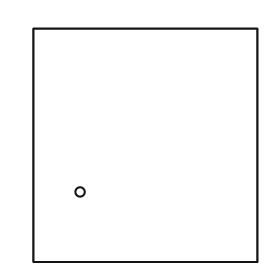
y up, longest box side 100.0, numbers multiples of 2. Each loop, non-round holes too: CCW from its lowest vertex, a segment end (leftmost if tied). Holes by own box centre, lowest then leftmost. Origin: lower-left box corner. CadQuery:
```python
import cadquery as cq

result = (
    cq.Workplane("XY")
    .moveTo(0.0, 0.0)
    .lineTo(96.0, 0.0)
    .lineTo(96.0, 100.0)
    .lineTo(0.0, 100.0)
    .close()
    .moveTo(20.0, 30.0)
    .circle(2.0)
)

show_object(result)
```